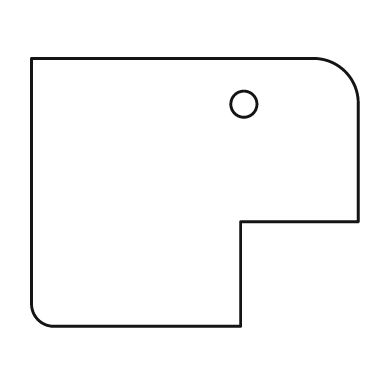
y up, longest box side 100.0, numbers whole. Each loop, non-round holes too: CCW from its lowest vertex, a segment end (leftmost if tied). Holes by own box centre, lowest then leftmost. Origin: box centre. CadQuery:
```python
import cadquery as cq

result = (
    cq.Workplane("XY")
    .moveTo(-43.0, -41.0)
    .lineTo(14.0, -41.0)
    .lineTo(14.0, -9.0)
    .lineTo(50.0, -9.0)
    .lineTo(50.0, 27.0)
    .threePointArc((46.0, 37.0), (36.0, 41.0))
    .lineTo(-50.0, 41.0)
    .lineTo(-50.0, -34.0)
    .threePointArc((-48.0, -39.0), (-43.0, -41.0))
    .close()
    .moveTo(15.0, 27.0)
    .circle(4.0)
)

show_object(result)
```